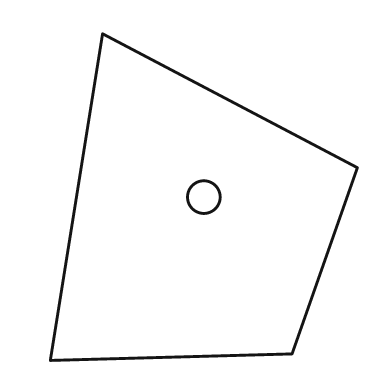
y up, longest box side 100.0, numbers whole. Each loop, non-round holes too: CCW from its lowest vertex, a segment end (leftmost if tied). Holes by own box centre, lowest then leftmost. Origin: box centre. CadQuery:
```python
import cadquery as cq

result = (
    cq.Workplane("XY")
    .moveTo(-47.0, -50.0)
    .lineTo(27.0, -48.0)
    .lineTo(47.0, 9.0)
    .lineTo(-31.0, 50.0)
    .close()
    .moveTo(0.0, 0.0)
    .circle(5.0)
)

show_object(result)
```